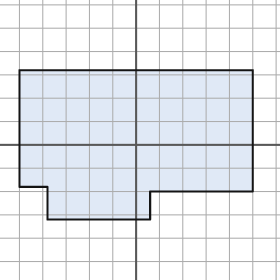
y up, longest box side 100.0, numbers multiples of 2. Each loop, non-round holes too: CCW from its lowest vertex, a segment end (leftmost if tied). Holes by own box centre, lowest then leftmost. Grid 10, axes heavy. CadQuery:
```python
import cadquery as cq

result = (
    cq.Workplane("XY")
    .moveTo(-38.0, -32.0)
    .lineTo(6.0, -32.0)
    .lineTo(6.0, -20.0)
    .lineTo(50.0, -20.0)
    .lineTo(50.0, 32.0)
    .lineTo(-50.0, 32.0)
    .lineTo(-50.0, -18.0)
    .lineTo(-38.0, -18.0)
    .close()
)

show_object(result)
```